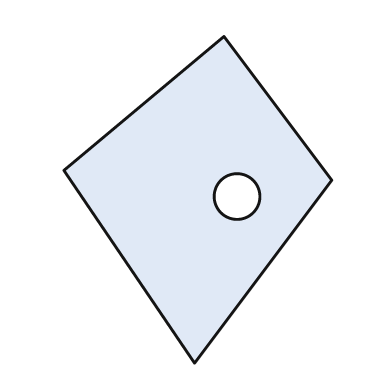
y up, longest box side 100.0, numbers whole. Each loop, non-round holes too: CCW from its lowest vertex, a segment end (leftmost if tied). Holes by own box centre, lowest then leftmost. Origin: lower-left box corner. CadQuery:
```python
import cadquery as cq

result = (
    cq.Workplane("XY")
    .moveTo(40.0, 0.0)
    .lineTo(82.0, 56.0)
    .lineTo(49.0, 100.0)
    .lineTo(0.0, 59.0)
    .close()
    .moveTo(53.0, 51.0)
    .circle(7.0)
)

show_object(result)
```